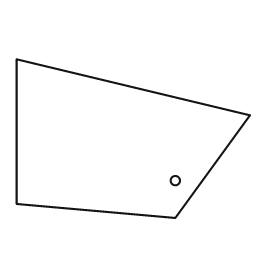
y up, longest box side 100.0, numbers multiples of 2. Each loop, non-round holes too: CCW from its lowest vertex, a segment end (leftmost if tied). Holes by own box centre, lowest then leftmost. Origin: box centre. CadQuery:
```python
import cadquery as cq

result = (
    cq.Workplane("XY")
    .moveTo(18.0, -34.0)
    .lineTo(50.0, 10.0)
    .lineTo(-50.0, 34.0)
    .lineTo(-50.0, -28.0)
    .close()
    .moveTo(18.0, -18.0)
    .circle(2.0)
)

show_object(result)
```